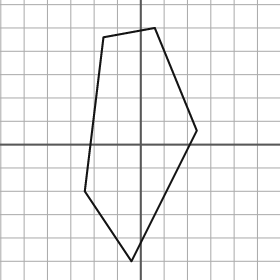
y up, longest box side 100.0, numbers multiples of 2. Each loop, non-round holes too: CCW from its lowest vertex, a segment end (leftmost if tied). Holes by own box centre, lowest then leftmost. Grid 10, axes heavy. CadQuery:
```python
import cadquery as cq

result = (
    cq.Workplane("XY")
    .moveTo(-4.0, -50.0)
    .lineTo(24.0, 6.0)
    .lineTo(6.0, 50.0)
    .lineTo(-16.0, 46.0)
    .lineTo(-24.0, -20.0)
    .close()
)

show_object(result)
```